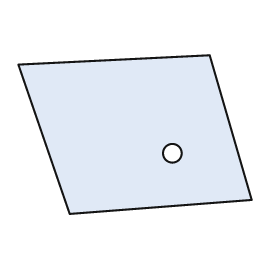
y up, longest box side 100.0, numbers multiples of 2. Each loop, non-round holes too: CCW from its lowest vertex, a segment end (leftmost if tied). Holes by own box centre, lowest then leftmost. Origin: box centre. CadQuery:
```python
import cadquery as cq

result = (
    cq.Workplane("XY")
    .moveTo(-28.0, -34.0)
    .lineTo(50.0, -28.0)
    .lineTo(32.0, 34.0)
    .lineTo(-50.0, 30.0)
    .close()
    .moveTo(16.0, -8.0)
    .circle(4.0)
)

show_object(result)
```